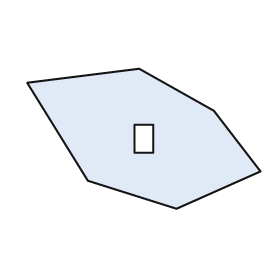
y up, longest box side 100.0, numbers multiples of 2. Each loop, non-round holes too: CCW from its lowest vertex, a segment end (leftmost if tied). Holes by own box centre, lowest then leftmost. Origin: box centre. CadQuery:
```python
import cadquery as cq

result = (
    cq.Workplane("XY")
    .moveTo(14.0, -30.0)
    .lineTo(50.0, -14.0)
    .lineTo(30.0, 12.0)
    .lineTo(-2.0, 30.0)
    .lineTo(-50.0, 24.0)
    .lineTo(-24.0, -18.0)
    .close()
    .moveTo(-4.0, -6.0)
    .lineTo(4.0, -6.0)
    .lineTo(4.0, 6.0)
    .lineTo(-4.0, 6.0)
    .close()
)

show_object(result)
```